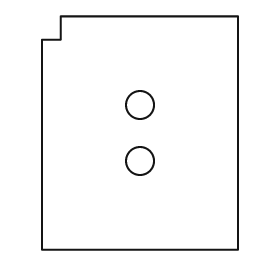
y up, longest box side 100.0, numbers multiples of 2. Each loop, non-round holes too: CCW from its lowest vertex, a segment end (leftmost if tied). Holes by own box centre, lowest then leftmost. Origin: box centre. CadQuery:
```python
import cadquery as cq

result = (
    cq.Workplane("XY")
    .moveTo(-42.0, -50.0)
    .lineTo(42.0, -50.0)
    .lineTo(42.0, 50.0)
    .lineTo(-34.0, 50.0)
    .lineTo(-34.0, 40.0)
    .lineTo(-42.0, 40.0)
    .close()
    .moveTo(0.0, -12.0)
    .circle(6.0)
    .moveTo(0.0, 12.0)
    .circle(6.0)
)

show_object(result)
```